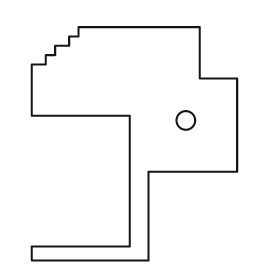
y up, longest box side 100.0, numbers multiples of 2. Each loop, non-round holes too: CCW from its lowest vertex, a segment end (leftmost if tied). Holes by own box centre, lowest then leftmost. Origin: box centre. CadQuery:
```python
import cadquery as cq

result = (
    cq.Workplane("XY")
    .moveTo(-44.0, -50.0)
    .lineTo(6.0, -50.0)
    .lineTo(6.0, -12.0)
    .lineTo(44.0, -12.0)
    .lineTo(44.0, 28.0)
    .lineTo(28.0, 28.0)
    .lineTo(28.0, 50.0)
    .lineTo(-24.0, 50.0)
    .lineTo(-24.0, 46.0)
    .lineTo(-28.0, 46.0)
    .lineTo(-28.0, 42.0)
    .lineTo(-34.0, 42.0)
    .lineTo(-34.0, 38.0)
    .lineTo(-38.0, 38.0)
    .lineTo(-38.0, 34.0)
    .lineTo(-44.0, 34.0)
    .lineTo(-44.0, 12.0)
    .lineTo(-2.0, 12.0)
    .lineTo(-2.0, -44.0)
    .lineTo(-44.0, -44.0)
    .close()
    .moveTo(22.0, 10.0)
    .circle(4.0)
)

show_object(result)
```